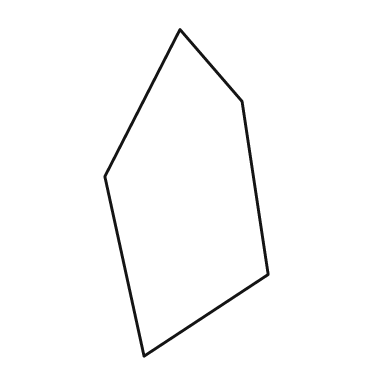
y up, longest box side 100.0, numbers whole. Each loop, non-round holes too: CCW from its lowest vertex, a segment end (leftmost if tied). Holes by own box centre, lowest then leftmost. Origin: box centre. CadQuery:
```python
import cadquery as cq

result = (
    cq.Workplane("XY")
    .moveTo(-13.0, -50.0)
    .lineTo(25.0, -25.0)
    .lineTo(17.0, 28.0)
    .lineTo(-2.0, 50.0)
    .lineTo(-25.0, 5.0)
    .close()
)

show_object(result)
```